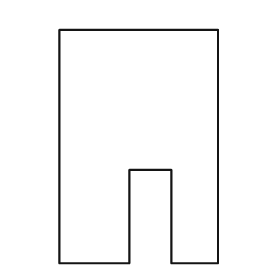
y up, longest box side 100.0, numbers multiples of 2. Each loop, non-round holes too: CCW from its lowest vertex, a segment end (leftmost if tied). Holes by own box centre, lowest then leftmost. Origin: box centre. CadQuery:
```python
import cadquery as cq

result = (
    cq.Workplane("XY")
    .moveTo(-34.0, -50.0)
    .lineTo(-4.0, -50.0)
    .lineTo(-4.0, -10.0)
    .lineTo(14.0, -10.0)
    .lineTo(14.0, -50.0)
    .lineTo(34.0, -50.0)
    .lineTo(34.0, 50.0)
    .lineTo(-34.0, 50.0)
    .close()
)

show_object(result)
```